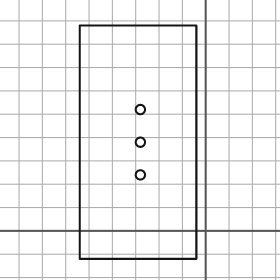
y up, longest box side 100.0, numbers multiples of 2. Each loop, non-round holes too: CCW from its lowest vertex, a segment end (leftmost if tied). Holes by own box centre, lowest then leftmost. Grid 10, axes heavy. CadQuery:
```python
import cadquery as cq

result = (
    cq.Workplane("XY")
    .moveTo(-54.0, -12.0)
    .lineTo(-4.0, -12.0)
    .lineTo(-4.0, 88.0)
    .lineTo(-54.0, 88.0)
    .close()
    .moveTo(-28.0, 24.0)
    .circle(2.0)
    .moveTo(-28.0, 38.0)
    .circle(2.0)
    .moveTo(-28.0, 52.0)
    .circle(2.0)
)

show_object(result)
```